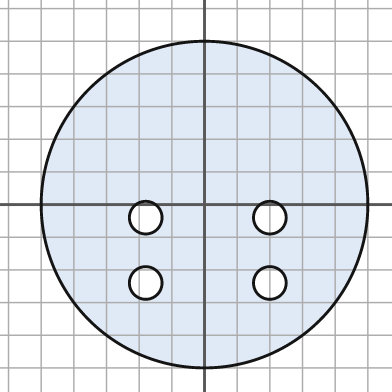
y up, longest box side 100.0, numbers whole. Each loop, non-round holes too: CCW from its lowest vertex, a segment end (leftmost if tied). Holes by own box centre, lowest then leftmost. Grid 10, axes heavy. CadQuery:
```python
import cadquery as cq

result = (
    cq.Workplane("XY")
    .moveTo(0.0, 0.0)
    .circle(50.0)
    .moveTo(-18.0, -24.0)
    .circle(5.0)
    .moveTo(20.0, -24.0)
    .circle(5.0)
    .moveTo(-18.0, -4.0)
    .circle(5.0)
    .moveTo(20.0, -4.0)
    .circle(5.0)
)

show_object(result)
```